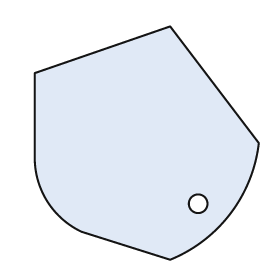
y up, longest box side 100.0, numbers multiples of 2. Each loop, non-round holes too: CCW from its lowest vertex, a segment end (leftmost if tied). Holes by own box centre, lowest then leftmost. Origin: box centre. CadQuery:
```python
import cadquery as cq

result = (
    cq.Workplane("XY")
    .moveTo(10.0, -50.0)
    .threePointArc((36.0, -30.0), (48.0, 0.0))
    .lineTo(10.0, 50.0)
    .lineTo(-48.0, 30.0)
    .lineTo(-48.0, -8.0)
    .threePointArc((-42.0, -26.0), (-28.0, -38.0))
    .close()
    .moveTo(22.0, -26.0)
    .circle(4.0)
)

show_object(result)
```